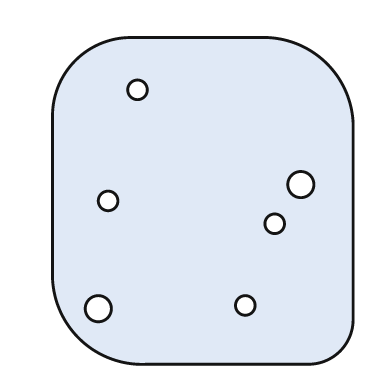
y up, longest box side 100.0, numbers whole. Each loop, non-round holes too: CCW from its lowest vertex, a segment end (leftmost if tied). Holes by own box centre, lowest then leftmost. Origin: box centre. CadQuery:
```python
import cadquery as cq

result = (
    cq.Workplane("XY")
    .moveTo(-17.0, -50.0)
    .lineTo(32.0, -50.0)
    .threePointArc((42.0, -46.0), (46.0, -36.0))
    .lineTo(46.0, 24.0)
    .threePointArc((38.0, 42.0), (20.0, 50.0))
    .lineTo(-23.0, 50.0)
    .threePointArc((-39.0, 43.0), (-46.0, 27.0))
    .lineTo(-46.0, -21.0)
    .threePointArc((-38.0, -42.0), (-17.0, -50.0))
    .close()
    .moveTo(-32.0, -33.0)
    .circle(4.0)
    .moveTo(13.0, -32.0)
    .circle(3.0)
    .moveTo(22.0, -7.0)
    .circle(3.0)
    .moveTo(-29.0, 0.0)
    .circle(3.0)
    .moveTo(30.0, 5.0)
    .circle(4.0)
    .moveTo(-20.0, 34.0)
    .circle(3.0)
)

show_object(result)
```